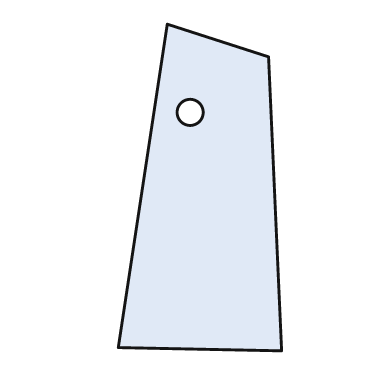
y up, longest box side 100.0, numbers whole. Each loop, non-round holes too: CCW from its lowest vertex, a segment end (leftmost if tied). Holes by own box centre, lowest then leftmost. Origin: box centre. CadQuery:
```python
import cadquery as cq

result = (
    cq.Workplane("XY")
    .moveTo(25.0, -50.0)
    .lineTo(21.0, 40.0)
    .lineTo(-10.0, 50.0)
    .lineTo(-25.0, -49.0)
    .close()
    .moveTo(-3.0, 23.0)
    .circle(4.0)
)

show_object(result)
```